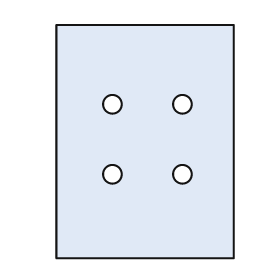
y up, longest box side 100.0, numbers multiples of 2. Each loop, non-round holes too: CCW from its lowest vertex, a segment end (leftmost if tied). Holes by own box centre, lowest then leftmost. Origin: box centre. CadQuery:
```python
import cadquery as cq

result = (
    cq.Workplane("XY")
    .moveTo(-38.0, -50.0)
    .lineTo(38.0, -50.0)
    .lineTo(38.0, 50.0)
    .lineTo(-38.0, 50.0)
    .close()
    .moveTo(-14.0, -14.0)
    .circle(4.0)
    .moveTo(16.0, -14.0)
    .circle(4.0)
    .moveTo(-14.0, 16.0)
    .circle(4.0)
    .moveTo(16.0, 16.0)
    .circle(4.0)
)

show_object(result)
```